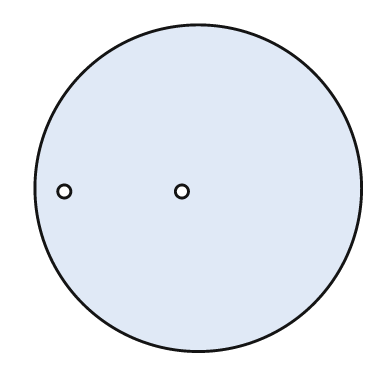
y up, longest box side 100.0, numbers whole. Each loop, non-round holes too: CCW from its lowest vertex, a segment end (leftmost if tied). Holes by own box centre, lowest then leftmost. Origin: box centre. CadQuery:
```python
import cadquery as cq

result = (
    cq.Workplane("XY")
    .moveTo(0.0, 0.0)
    .circle(50.0)
    .moveTo(-41.0, -1.0)
    .circle(2.0)
    .moveTo(-5.0, -1.0)
    .circle(2.0)
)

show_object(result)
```